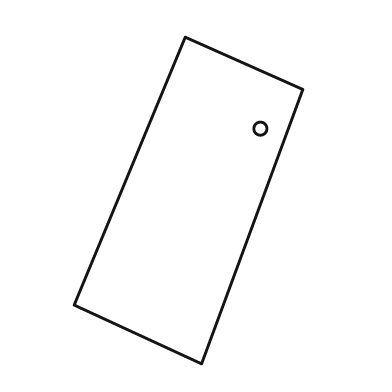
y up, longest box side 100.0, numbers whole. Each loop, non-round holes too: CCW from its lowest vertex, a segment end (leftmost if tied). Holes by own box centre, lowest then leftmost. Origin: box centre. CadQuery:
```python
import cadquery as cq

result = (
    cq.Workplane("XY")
    .moveTo(4.0, -50.0)
    .lineTo(35.0, 34.0)
    .lineTo(-1.0, 50.0)
    .lineTo(-35.0, -32.0)
    .close()
    .moveTo(22.0, 22.0)
    .circle(2.0)
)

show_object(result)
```